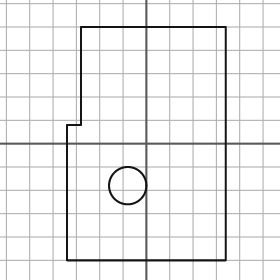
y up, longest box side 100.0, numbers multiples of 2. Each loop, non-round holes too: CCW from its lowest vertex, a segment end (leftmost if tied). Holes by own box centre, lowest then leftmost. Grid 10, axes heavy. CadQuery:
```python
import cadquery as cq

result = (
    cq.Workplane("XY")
    .moveTo(-34.0, -50.0)
    .lineTo(34.0, -50.0)
    .lineTo(34.0, 50.0)
    .lineTo(-28.0, 50.0)
    .lineTo(-28.0, 8.0)
    .lineTo(-34.0, 8.0)
    .close()
    .moveTo(-8.0, -18.0)
    .circle(8.0)
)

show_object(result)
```